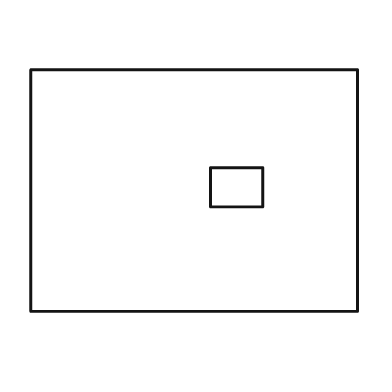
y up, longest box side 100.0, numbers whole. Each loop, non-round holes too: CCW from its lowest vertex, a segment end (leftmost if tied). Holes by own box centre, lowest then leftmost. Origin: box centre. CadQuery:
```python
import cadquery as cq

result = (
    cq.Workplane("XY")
    .moveTo(-50.0, -37.0)
    .lineTo(50.0, -37.0)
    .lineTo(50.0, 37.0)
    .lineTo(-50.0, 37.0)
    .close()
    .moveTo(5.0, -5.0)
    .lineTo(21.0, -5.0)
    .lineTo(21.0, 7.0)
    .lineTo(5.0, 7.0)
    .close()
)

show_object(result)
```